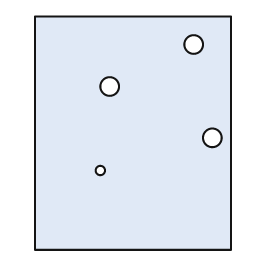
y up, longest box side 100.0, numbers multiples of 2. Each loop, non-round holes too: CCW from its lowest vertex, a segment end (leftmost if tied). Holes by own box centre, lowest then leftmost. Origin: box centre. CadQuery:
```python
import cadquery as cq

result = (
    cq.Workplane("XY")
    .moveTo(-42.0, -50.0)
    .lineTo(42.0, -50.0)
    .lineTo(42.0, 50.0)
    .lineTo(-42.0, 50.0)
    .close()
    .moveTo(-14.0, -16.0)
    .circle(2.0)
    .moveTo(34.0, -2.0)
    .circle(4.0)
    .moveTo(-10.0, 20.0)
    .circle(4.0)
    .moveTo(26.0, 38.0)
    .circle(4.0)
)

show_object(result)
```